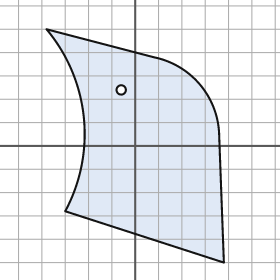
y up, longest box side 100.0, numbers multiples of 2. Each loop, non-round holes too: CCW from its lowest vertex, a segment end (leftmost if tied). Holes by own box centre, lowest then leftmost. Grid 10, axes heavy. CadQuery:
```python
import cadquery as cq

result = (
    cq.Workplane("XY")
    .moveTo(38.0, -50.0)
    .lineTo(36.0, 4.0)
    .threePointArc((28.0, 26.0), (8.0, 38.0))
    .lineTo(-38.0, 50.0)
    .threePointArc((-22.0, 12.0), (-30.0, -28.0))
    .close()
    .moveTo(-6.0, 24.0)
    .circle(2.0)
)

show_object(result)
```